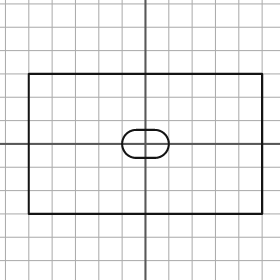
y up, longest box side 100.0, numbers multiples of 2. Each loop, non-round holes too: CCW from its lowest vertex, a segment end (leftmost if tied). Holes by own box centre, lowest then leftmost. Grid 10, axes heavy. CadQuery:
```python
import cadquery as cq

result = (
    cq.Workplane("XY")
    .moveTo(-50.0, -30.0)
    .lineTo(50.0, -30.0)
    .lineTo(50.0, 30.0)
    .lineTo(-50.0, 30.0)
    .close()
    .moveTo(-4.0, -6.0)
    .lineTo(4.0, -6.0)
    .threePointArc((10.0, 0.0), (4.0, 6.0))
    .lineTo(-4.0, 6.0)
    .threePointArc((-10.0, 0.0), (-4.0, -6.0))
    .close()
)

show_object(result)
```